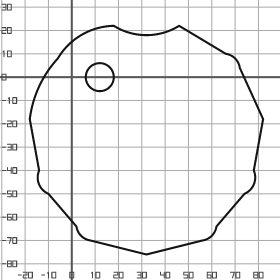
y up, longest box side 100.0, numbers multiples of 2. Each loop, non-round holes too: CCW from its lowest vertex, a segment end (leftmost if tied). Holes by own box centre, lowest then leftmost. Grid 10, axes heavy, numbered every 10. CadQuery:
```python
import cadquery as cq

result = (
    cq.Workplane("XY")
    .moveTo(32.0, -76.0)
    .lineTo(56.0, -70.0)
    .threePointArc((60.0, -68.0), (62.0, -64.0))
    .lineTo(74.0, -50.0)
    .threePointArc((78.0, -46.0), (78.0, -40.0))
    .lineTo(82.0, -18.0)
    .lineTo(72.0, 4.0)
    .threePointArc((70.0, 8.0), (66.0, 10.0))
    .lineTo(46.0, 22.0)
    .threePointArc((32.0, 18.0), (18.0, 22.0))
    .threePointArc((4.0, 18.0), (-6.0, 8.0))
    .threePointArc((-14.0, -4.0), (-18.0, -18.0))
    .lineTo(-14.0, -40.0)
    .threePointArc((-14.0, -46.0), (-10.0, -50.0))
    .lineTo(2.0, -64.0)
    .threePointArc((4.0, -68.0), (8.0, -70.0))
    .close()
    .moveTo(12.0, 0.0)
    .circle(6.0)
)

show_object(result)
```